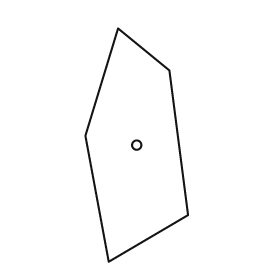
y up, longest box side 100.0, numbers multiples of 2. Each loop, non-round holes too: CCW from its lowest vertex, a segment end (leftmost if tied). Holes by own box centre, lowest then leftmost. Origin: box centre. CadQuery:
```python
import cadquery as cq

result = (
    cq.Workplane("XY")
    .moveTo(-12.0, -50.0)
    .lineTo(22.0, -30.0)
    .lineTo(14.0, 32.0)
    .lineTo(-8.0, 50.0)
    .lineTo(-22.0, 4.0)
    .close()
    .moveTo(0.0, 0.0)
    .circle(2.0)
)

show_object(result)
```